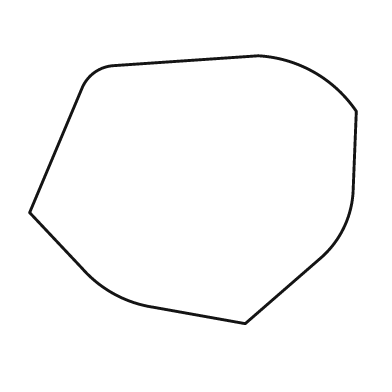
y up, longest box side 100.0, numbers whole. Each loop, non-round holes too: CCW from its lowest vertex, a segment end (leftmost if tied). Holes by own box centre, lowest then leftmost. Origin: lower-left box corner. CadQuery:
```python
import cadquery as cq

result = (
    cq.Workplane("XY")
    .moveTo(66.0, 0.0)
    .lineTo(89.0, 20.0)
    .threePointArc((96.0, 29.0), (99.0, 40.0))
    .lineTo(100.0, 65.0)
    .threePointArc((87.0, 77.0), (70.0, 82.0))
    .lineTo(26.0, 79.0)
    .threePointArc((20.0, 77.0), (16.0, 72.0))
    .lineTo(0.0, 34.0)
    .lineTo(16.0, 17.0)
    .threePointArc((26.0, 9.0), (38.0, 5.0))
    .close()
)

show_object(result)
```